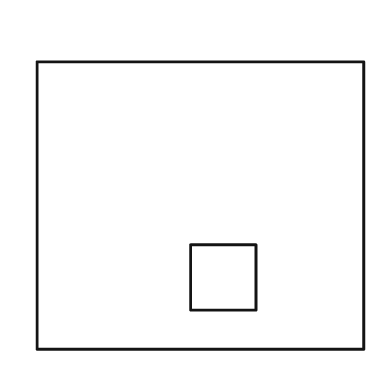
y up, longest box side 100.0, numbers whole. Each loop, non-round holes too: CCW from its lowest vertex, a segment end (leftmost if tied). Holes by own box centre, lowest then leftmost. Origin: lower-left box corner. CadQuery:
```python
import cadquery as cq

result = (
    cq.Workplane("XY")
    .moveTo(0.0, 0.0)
    .lineTo(100.0, 0.0)
    .lineTo(100.0, 88.0)
    .lineTo(0.0, 88.0)
    .close()
    .moveTo(47.0, 12.0)
    .lineTo(67.0, 12.0)
    .lineTo(67.0, 32.0)
    .lineTo(47.0, 32.0)
    .close()
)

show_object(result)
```